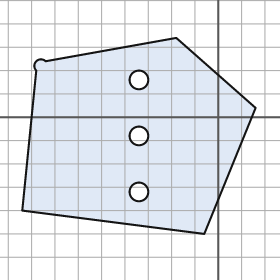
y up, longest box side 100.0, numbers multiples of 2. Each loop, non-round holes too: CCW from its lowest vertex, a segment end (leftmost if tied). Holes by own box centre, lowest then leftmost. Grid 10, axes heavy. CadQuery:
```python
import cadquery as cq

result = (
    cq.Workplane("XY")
    .moveTo(-6.0, -50.0)
    .lineTo(16.0, 4.0)
    .lineTo(-18.0, 34.0)
    .lineTo(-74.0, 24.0)
    .threePointArc((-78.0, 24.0), (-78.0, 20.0))
    .lineTo(-84.0, -40.0)
    .close()
    .moveTo(-34.0, -32.0)
    .circle(4.0)
    .moveTo(-34.0, -8.0)
    .circle(4.0)
    .moveTo(-34.0, 16.0)
    .circle(4.0)
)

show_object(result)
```